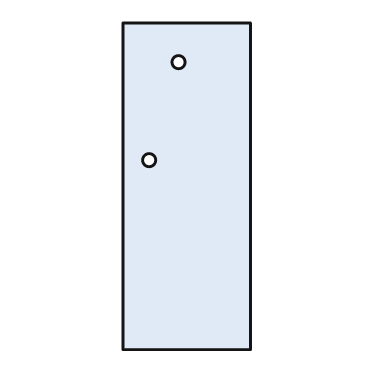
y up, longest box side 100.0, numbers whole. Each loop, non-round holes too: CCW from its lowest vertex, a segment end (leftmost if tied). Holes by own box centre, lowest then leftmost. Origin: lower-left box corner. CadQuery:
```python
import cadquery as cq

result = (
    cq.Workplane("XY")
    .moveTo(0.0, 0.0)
    .lineTo(39.0, 0.0)
    .lineTo(39.0, 100.0)
    .lineTo(0.0, 100.0)
    .close()
    .moveTo(8.0, 58.0)
    .circle(2.0)
    .moveTo(17.0, 88.0)
    .circle(2.0)
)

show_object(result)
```